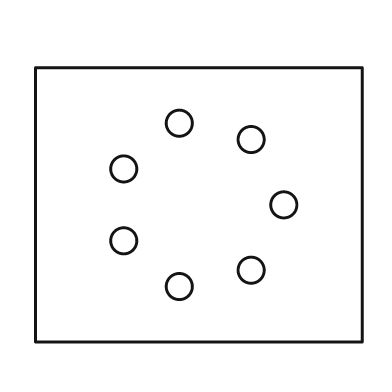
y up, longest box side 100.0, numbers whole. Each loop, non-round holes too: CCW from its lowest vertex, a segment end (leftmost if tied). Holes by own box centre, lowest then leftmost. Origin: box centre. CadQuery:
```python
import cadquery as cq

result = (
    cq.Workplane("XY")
    .moveTo(-50.0, -42.0)
    .lineTo(50.0, -42.0)
    .lineTo(50.0, 42.0)
    .lineTo(-50.0, 42.0)
    .close()
    .moveTo(-6.0, -25.0)
    .circle(4.0)
    .moveTo(16.0, -20.0)
    .circle(4.0)
    .moveTo(-23.0, -11.0)
    .circle(4.0)
    .moveTo(26.0, 0.0)
    .circle(4.0)
    .moveTo(-23.0, 11.0)
    .circle(4.0)
    .moveTo(16.0, 20.0)
    .circle(4.0)
    .moveTo(-6.0, 25.0)
    .circle(4.0)
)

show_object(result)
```